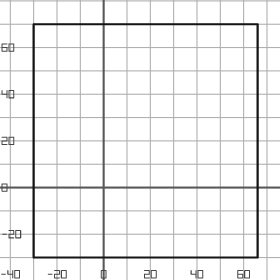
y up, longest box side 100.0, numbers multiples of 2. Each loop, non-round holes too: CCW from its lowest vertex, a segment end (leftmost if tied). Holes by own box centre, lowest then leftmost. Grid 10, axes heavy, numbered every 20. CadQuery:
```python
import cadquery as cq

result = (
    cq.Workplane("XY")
    .moveTo(-30.0, -30.0)
    .lineTo(66.0, -30.0)
    .lineTo(66.0, 70.0)
    .lineTo(-30.0, 70.0)
    .close()
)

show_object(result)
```